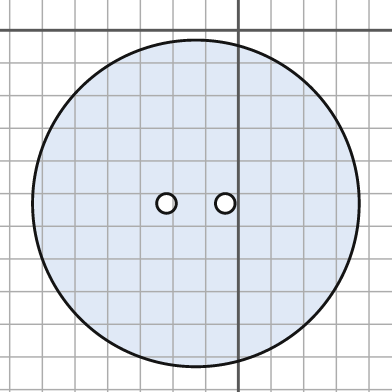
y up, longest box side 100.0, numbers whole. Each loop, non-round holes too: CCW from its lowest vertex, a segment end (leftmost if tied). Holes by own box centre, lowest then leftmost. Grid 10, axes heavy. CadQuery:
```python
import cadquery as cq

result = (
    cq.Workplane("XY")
    .moveTo(-13.0, -53.0)
    .circle(50.0)
    .moveTo(-22.0, -53.0)
    .circle(3.0)
    .moveTo(-4.0, -53.0)
    .circle(3.0)
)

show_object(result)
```